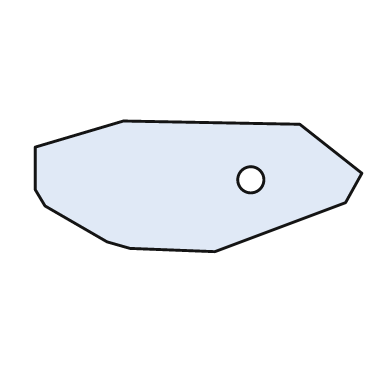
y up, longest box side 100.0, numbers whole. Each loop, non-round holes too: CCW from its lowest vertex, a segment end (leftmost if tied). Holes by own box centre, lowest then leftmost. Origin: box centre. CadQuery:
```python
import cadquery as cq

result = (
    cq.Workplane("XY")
    .moveTo(5.0, -20.0)
    .lineTo(45.0, -5.0)
    .lineTo(50.0, 4.0)
    .lineTo(31.0, 19.0)
    .lineTo(-23.0, 20.0)
    .lineTo(-50.0, 12.0)
    .lineTo(-50.0, -1.0)
    .lineTo(-47.0, -6.0)
    .lineTo(-28.0, -17.0)
    .lineTo(-21.0, -19.0)
    .close()
    .moveTo(16.0, 2.0)
    .circle(4.0)
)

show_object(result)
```